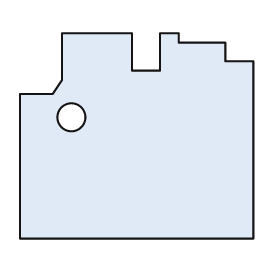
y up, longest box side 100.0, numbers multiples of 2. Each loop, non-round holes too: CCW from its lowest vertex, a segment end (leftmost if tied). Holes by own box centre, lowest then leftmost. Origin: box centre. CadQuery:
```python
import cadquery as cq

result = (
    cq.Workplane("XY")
    .moveTo(-50.0, -44.0)
    .lineTo(50.0, -44.0)
    .lineTo(50.0, 32.0)
    .lineTo(38.0, 32.0)
    .lineTo(38.0, 40.0)
    .lineTo(18.0, 40.0)
    .lineTo(18.0, 44.0)
    .lineTo(10.0, 44.0)
    .lineTo(10.0, 28.0)
    .lineTo(-2.0, 28.0)
    .lineTo(-2.0, 44.0)
    .lineTo(-32.0, 44.0)
    .lineTo(-32.0, 24.0)
    .lineTo(-36.0, 18.0)
    .lineTo(-50.0, 18.0)
    .close()
    .moveTo(-28.0, 8.0)
    .circle(6.0)
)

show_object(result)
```